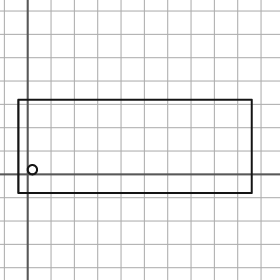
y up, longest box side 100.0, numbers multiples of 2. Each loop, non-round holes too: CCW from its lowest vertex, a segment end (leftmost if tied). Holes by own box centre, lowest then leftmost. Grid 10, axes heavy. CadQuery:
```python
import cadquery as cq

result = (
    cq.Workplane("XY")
    .moveTo(-4.0, -8.0)
    .lineTo(96.0, -8.0)
    .lineTo(96.0, 32.0)
    .lineTo(-4.0, 32.0)
    .close()
    .moveTo(2.0, 2.0)
    .circle(2.0)
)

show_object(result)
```